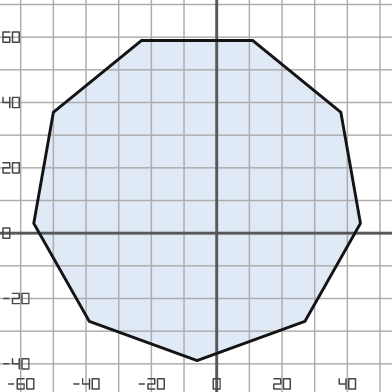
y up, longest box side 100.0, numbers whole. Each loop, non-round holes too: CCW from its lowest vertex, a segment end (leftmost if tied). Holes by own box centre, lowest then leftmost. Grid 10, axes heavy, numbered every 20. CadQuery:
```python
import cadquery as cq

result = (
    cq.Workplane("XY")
    .moveTo(-6.0, -39.0)
    .lineTo(27.0, -27.0)
    .lineTo(44.0, 3.0)
    .lineTo(38.0, 37.0)
    .lineTo(11.0, 59.0)
    .lineTo(-23.0, 59.0)
    .lineTo(-50.0, 37.0)
    .lineTo(-56.0, 3.0)
    .lineTo(-39.0, -27.0)
    .close()
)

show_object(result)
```